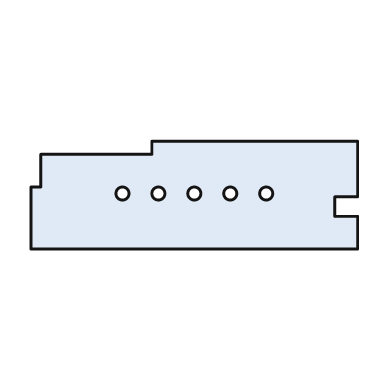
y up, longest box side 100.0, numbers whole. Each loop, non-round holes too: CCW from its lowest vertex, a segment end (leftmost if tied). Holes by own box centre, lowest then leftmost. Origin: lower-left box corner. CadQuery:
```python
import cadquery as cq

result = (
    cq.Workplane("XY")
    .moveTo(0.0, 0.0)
    .lineTo(100.0, 0.0)
    .lineTo(100.0, 10.0)
    .lineTo(93.0, 10.0)
    .lineTo(93.0, 16.0)
    .lineTo(100.0, 16.0)
    .lineTo(100.0, 33.0)
    .lineTo(37.0, 33.0)
    .lineTo(37.0, 29.0)
    .lineTo(3.0, 29.0)
    .lineTo(3.0, 19.0)
    .lineTo(0.0, 19.0)
    .close()
    .moveTo(28.0, 17.0)
    .circle(2.0)
    .moveTo(39.0, 17.0)
    .circle(2.0)
    .moveTo(50.0, 17.0)
    .circle(2.0)
    .moveTo(61.0, 17.0)
    .circle(2.0)
    .moveTo(72.0, 17.0)
    .circle(2.0)
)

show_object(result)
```